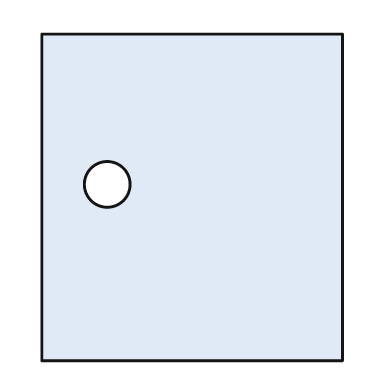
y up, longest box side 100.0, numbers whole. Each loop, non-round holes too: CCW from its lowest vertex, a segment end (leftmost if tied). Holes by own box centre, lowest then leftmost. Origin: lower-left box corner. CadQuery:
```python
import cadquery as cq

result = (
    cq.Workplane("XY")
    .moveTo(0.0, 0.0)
    .lineTo(92.0, 0.0)
    .lineTo(92.0, 100.0)
    .lineTo(0.0, 100.0)
    .close()
    .moveTo(20.0, 54.0)
    .circle(7.0)
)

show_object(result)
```